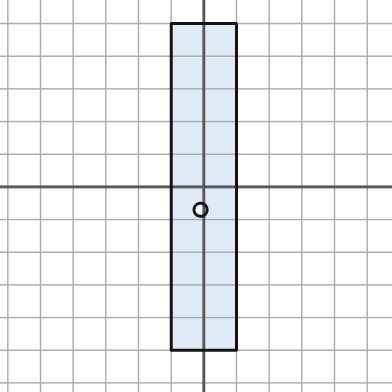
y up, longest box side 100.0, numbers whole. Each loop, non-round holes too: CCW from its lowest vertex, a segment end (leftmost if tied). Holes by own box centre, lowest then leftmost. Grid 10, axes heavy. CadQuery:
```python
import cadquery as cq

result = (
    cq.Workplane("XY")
    .moveTo(-10.0, -50.0)
    .lineTo(10.0, -50.0)
    .lineTo(10.0, 50.0)
    .lineTo(-10.0, 50.0)
    .close()
    .moveTo(-1.0, -7.0)
    .circle(2.0)
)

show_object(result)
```